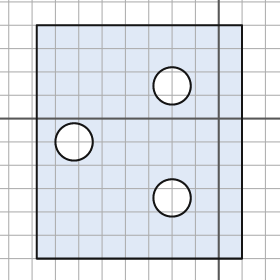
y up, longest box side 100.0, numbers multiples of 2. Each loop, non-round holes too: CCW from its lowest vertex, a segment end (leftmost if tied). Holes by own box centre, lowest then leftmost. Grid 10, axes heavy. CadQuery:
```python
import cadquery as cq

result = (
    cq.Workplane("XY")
    .moveTo(-78.0, -60.0)
    .lineTo(10.0, -60.0)
    .lineTo(10.0, 40.0)
    .lineTo(-78.0, 40.0)
    .close()
    .moveTo(-20.0, -34.0)
    .circle(8.0)
    .moveTo(-62.0, -10.0)
    .circle(8.0)
    .moveTo(-20.0, 14.0)
    .circle(8.0)
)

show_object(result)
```